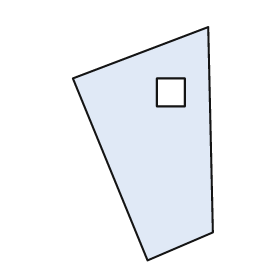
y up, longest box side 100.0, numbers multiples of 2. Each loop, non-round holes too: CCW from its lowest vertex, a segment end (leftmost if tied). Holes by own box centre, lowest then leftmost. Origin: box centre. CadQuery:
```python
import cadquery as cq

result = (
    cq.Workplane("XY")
    .moveTo(2.0, -50.0)
    .lineTo(30.0, -38.0)
    .lineTo(28.0, 50.0)
    .lineTo(-30.0, 28.0)
    .close()
    .moveTo(6.0, 16.0)
    .lineTo(18.0, 16.0)
    .lineTo(18.0, 28.0)
    .lineTo(6.0, 28.0)
    .close()
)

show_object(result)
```